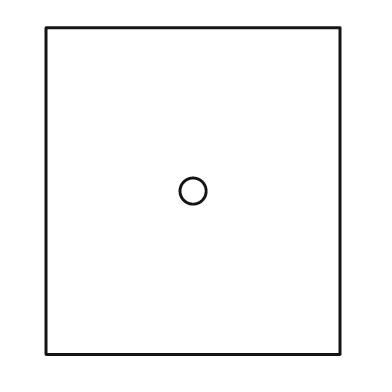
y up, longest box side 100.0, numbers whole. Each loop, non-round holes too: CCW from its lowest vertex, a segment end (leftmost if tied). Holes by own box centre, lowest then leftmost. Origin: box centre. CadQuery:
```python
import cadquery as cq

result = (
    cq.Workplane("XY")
    .moveTo(-45.0, -50.0)
    .lineTo(45.0, -50.0)
    .lineTo(45.0, 50.0)
    .lineTo(-45.0, 50.0)
    .close()
    .moveTo(0.0, 0.0)
    .circle(4.0)
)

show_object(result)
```